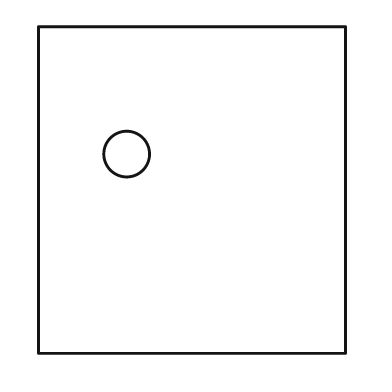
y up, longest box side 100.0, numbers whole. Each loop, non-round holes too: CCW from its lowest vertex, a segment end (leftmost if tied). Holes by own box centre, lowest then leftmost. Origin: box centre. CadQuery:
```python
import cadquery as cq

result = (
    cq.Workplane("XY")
    .moveTo(-47.0, -50.0)
    .lineTo(47.0, -50.0)
    .lineTo(47.0, 50.0)
    .lineTo(-47.0, 50.0)
    .close()
    .moveTo(-20.0, 11.0)
    .circle(7.0)
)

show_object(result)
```